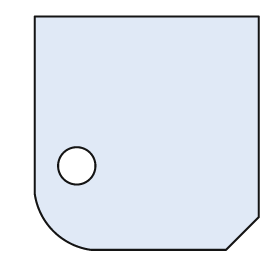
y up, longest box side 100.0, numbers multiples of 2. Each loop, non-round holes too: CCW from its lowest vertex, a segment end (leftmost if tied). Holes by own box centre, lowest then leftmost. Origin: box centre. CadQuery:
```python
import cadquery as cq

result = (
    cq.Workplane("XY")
    .moveTo(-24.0, -50.0)
    .lineTo(34.0, -50.0)
    .lineTo(48.0, -36.0)
    .lineTo(48.0, 50.0)
    .lineTo(-48.0, 50.0)
    .lineTo(-48.0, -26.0)
    .threePointArc((-40.0, -42.0), (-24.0, -50.0))
    .close()
    .moveTo(-30.0, -14.0)
    .circle(8.0)
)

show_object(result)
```